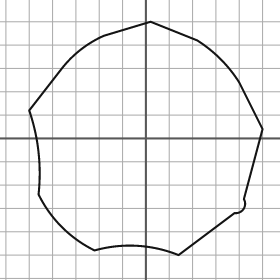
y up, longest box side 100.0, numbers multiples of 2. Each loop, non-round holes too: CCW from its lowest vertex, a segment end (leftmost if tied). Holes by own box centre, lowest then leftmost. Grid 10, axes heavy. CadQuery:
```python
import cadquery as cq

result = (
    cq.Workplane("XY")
    .moveTo(14.0, -50.0)
    .lineTo(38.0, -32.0)
    .threePointArc((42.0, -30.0), (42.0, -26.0))
    .lineTo(50.0, 4.0)
    .lineTo(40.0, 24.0)
    .threePointArc((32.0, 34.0), (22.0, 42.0))
    .lineTo(2.0, 50.0)
    .lineTo(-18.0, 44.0)
    .threePointArc((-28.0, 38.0), (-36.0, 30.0))
    .lineTo(-50.0, 12.0)
    .threePointArc((-46.0, -6.0), (-46.0, -24.0))
    .threePointArc((-36.0, -38.0), (-22.0, -48.0))
    .threePointArc((-4.0, -46.0), (14.0, -50.0))
    .close()
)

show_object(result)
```